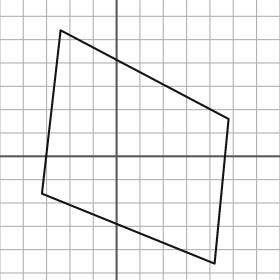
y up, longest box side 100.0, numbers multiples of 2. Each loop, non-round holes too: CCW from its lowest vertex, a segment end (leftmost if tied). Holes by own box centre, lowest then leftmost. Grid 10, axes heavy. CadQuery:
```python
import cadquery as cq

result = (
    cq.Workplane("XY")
    .moveTo(42.0, -46.0)
    .lineTo(48.0, 16.0)
    .lineTo(-24.0, 54.0)
    .lineTo(-32.0, -16.0)
    .close()
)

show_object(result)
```